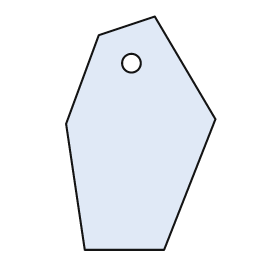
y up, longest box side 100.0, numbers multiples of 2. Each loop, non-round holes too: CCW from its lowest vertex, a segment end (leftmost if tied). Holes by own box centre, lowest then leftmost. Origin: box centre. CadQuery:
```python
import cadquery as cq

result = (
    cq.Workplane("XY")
    .moveTo(-24.0, -50.0)
    .lineTo(10.0, -50.0)
    .lineTo(32.0, 6.0)
    .lineTo(6.0, 50.0)
    .lineTo(-18.0, 42.0)
    .lineTo(-32.0, 4.0)
    .close()
    .moveTo(-4.0, 30.0)
    .circle(4.0)
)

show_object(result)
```